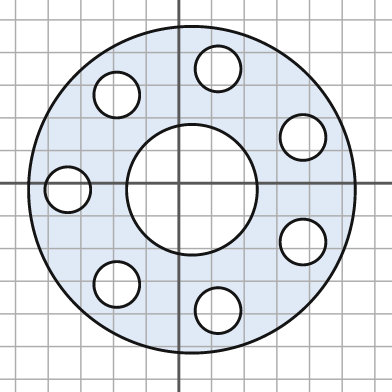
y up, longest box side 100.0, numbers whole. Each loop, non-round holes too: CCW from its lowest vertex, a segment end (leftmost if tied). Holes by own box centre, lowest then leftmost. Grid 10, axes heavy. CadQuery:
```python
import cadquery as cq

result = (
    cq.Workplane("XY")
    .moveTo(4.0, -2.0)
    .circle(50.0)
    .moveTo(12.0, -39.0)
    .circle(7.0)
    .moveTo(-19.0, -31.0)
    .circle(7.0)
    .moveTo(38.0, -18.0)
    .circle(7.0)
    .moveTo(-34.0, -2.0)
    .circle(7.0)
    .moveTo(4.0, -2.0)
    .circle(20.0)
    .moveTo(38.0, 14.0)
    .circle(7.0)
    .moveTo(-19.0, 27.0)
    .circle(7.0)
    .moveTo(12.0, 35.0)
    .circle(7.0)
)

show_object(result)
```